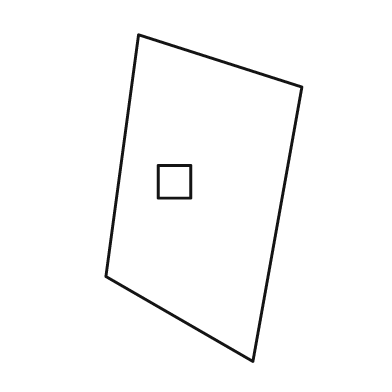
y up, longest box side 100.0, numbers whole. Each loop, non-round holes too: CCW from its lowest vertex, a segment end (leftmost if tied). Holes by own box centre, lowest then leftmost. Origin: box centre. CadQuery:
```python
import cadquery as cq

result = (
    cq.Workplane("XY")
    .moveTo(15.0, -50.0)
    .lineTo(30.0, 34.0)
    .lineTo(-20.0, 50.0)
    .lineTo(-30.0, -24.0)
    .close()
    .moveTo(-14.0, 0.0)
    .lineTo(-4.0, 0.0)
    .lineTo(-4.0, 10.0)
    .lineTo(-14.0, 10.0)
    .close()
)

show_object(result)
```